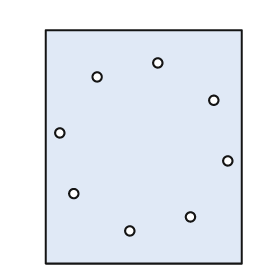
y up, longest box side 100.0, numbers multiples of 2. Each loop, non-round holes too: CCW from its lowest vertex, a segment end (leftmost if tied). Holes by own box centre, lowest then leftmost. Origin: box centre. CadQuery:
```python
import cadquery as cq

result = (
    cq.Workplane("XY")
    .moveTo(-42.0, -50.0)
    .lineTo(42.0, -50.0)
    .lineTo(42.0, 50.0)
    .lineTo(-42.0, 50.0)
    .close()
    .moveTo(-6.0, -36.0)
    .circle(2.0)
    .moveTo(20.0, -30.0)
    .circle(2.0)
    .moveTo(-30.0, -20.0)
    .circle(2.0)
    .moveTo(36.0, -6.0)
    .circle(2.0)
    .moveTo(-36.0, 6.0)
    .circle(2.0)
    .moveTo(30.0, 20.0)
    .circle(2.0)
    .moveTo(-20.0, 30.0)
    .circle(2.0)
    .moveTo(6.0, 36.0)
    .circle(2.0)
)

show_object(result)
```